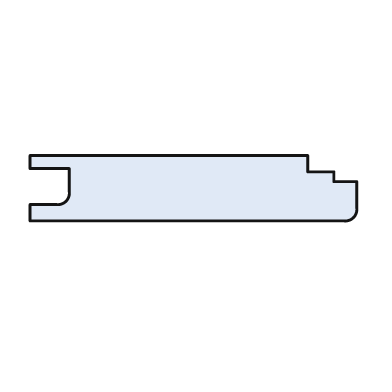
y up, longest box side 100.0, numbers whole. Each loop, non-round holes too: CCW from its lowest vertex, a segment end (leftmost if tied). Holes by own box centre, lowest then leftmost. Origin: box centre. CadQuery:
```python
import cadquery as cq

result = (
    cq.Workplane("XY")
    .moveTo(-50.0, -10.0)
    .lineTo(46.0, -10.0)
    .threePointArc((49.0, -9.0), (50.0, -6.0))
    .lineTo(50.0, 2.0)
    .lineTo(43.0, 2.0)
    .lineTo(43.0, 5.0)
    .lineTo(35.0, 5.0)
    .lineTo(35.0, 10.0)
    .lineTo(-50.0, 10.0)
    .lineTo(-50.0, 6.0)
    .lineTo(-38.0, 6.0)
    .lineTo(-38.0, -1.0)
    .threePointArc((-39.0, -4.0), (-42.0, -5.0))
    .lineTo(-50.0, -5.0)
    .close()
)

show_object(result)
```